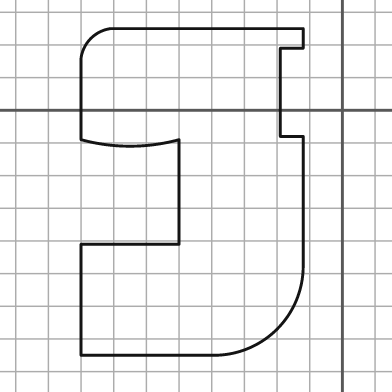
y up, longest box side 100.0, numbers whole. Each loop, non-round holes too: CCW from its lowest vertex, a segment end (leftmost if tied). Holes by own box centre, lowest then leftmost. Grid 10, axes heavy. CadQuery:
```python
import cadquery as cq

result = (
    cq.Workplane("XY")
    .moveTo(-80.0, -75.0)
    .lineTo(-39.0, -75.0)
    .threePointArc((-20.0, -67.0), (-12.0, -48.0))
    .lineTo(-12.0, -8.0)
    .lineTo(-19.0, -8.0)
    .lineTo(-19.0, 19.0)
    .lineTo(-12.0, 19.0)
    .lineTo(-12.0, 25.0)
    .lineTo(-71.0, 25.0)
    .threePointArc((-77.0, 22.0), (-80.0, 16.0))
    .lineTo(-80.0, -9.0)
    .threePointArc((-65.0, -11.0), (-50.0, -9.0))
    .lineTo(-50.0, -41.0)
    .lineTo(-80.0, -41.0)
    .close()
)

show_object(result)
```